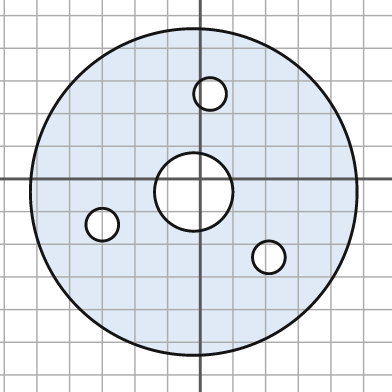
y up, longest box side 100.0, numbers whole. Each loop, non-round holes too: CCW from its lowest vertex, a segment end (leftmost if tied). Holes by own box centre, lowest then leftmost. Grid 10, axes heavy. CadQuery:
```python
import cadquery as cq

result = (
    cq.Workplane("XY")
    .moveTo(-2.0, -4.0)
    .circle(50.0)
    .moveTo(21.0, -24.0)
    .circle(5.0)
    .moveTo(-30.0, -14.0)
    .circle(5.0)
    .moveTo(-2.0, -4.0)
    .circle(12.0)
    .moveTo(3.0, 26.0)
    .circle(5.0)
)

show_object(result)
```